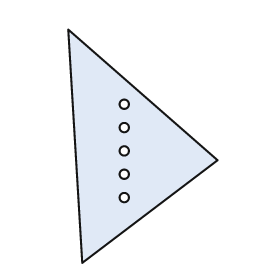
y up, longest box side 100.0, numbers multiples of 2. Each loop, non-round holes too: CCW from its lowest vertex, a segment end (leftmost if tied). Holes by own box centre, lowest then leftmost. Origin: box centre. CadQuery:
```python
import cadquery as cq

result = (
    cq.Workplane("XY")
    .moveTo(-26.0, -50.0)
    .lineTo(32.0, -6.0)
    .lineTo(-32.0, 50.0)
    .close()
    .moveTo(-8.0, -22.0)
    .circle(2.0)
    .moveTo(-8.0, -12.0)
    .circle(2.0)
    .moveTo(-8.0, -2.0)
    .circle(2.0)
    .moveTo(-8.0, 8.0)
    .circle(2.0)
    .moveTo(-8.0, 18.0)
    .circle(2.0)
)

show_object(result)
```